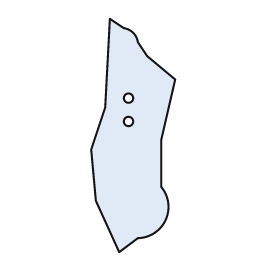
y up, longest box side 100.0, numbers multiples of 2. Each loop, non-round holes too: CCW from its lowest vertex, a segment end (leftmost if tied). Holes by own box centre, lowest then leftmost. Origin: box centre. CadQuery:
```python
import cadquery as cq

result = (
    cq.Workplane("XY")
    .moveTo(-6.0, -50.0)
    .lineTo(2.0, -44.0)
    .threePointArc((14.0, -36.0), (12.0, -22.0))
    .lineTo(12.0, -2.0)
    .lineTo(18.0, 24.0)
    .lineTo(6.0, 34.0)
    .lineTo(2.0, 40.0)
    .threePointArc((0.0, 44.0), (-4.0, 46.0))
    .lineTo(-10.0, 50.0)
    .lineTo(-12.0, 12.0)
    .lineTo(-18.0, -6.0)
    .lineTo(-16.0, -28.0)
    .close()
    .moveTo(-2.0, 6.0)
    .circle(2.0)
    .moveTo(-2.0, 16.0)
    .circle(2.0)
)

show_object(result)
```